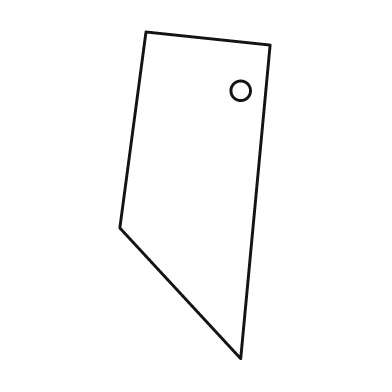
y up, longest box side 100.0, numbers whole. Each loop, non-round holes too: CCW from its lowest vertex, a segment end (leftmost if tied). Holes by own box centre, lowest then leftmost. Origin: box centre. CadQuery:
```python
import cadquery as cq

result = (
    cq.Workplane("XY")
    .moveTo(14.0, -50.0)
    .lineTo(23.0, 46.0)
    .lineTo(-15.0, 50.0)
    .lineTo(-23.0, -10.0)
    .close()
    .moveTo(14.0, 32.0)
    .circle(3.0)
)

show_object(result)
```